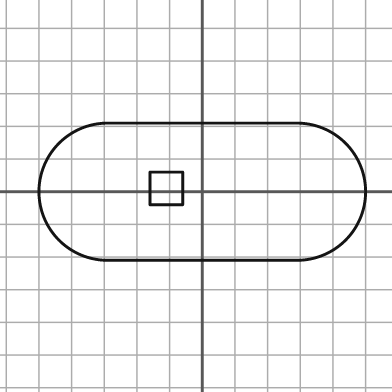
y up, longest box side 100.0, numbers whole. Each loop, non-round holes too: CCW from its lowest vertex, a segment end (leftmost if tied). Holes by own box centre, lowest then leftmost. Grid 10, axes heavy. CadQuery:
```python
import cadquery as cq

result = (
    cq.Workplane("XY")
    .moveTo(-29.0, -21.0)
    .lineTo(29.0, -21.0)
    .threePointArc((50.0, 0.0), (29.0, 21.0))
    .lineTo(-29.0, 21.0)
    .threePointArc((-50.0, 0.0), (-29.0, -21.0))
    .close()
    .moveTo(-16.0, -4.0)
    .lineTo(-6.0, -4.0)
    .lineTo(-6.0, 6.0)
    .lineTo(-16.0, 6.0)
    .close()
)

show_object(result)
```